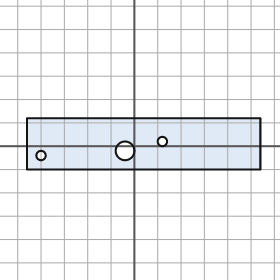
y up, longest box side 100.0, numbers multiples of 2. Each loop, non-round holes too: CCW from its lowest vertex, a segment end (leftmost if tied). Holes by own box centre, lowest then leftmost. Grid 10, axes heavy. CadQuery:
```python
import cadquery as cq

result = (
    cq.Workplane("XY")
    .moveTo(-46.0, -10.0)
    .lineTo(54.0, -10.0)
    .lineTo(54.0, 12.0)
    .lineTo(-46.0, 12.0)
    .close()
    .moveTo(-40.0, -4.0)
    .circle(2.0)
    .moveTo(-4.0, -2.0)
    .circle(4.0)
    .moveTo(12.0, 2.0)
    .circle(2.0)
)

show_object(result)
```